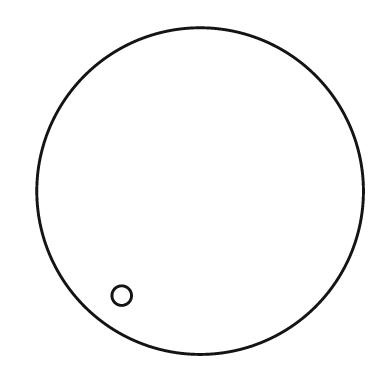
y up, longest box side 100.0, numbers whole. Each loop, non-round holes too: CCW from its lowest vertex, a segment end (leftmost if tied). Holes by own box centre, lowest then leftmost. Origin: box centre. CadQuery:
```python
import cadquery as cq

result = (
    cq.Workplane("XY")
    .moveTo(0.0, 0.0)
    .circle(50.0)
    .moveTo(-24.0, -32.0)
    .circle(3.0)
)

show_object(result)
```